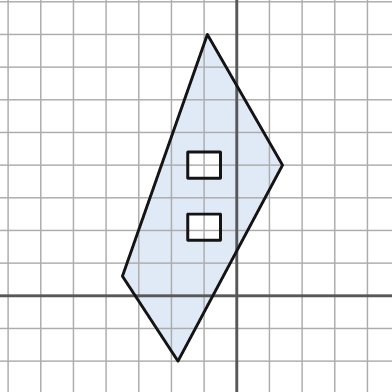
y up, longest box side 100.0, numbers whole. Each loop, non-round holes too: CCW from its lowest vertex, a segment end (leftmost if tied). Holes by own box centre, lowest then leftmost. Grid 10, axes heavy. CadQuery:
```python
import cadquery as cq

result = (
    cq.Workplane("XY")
    .moveTo(-18.0, -20.0)
    .lineTo(14.0, 40.0)
    .lineTo(-9.0, 80.0)
    .lineTo(-35.0, 6.0)
    .close()
    .moveTo(-15.0, 17.0)
    .lineTo(-5.0, 17.0)
    .lineTo(-5.0, 25.0)
    .lineTo(-15.0, 25.0)
    .close()
    .moveTo(-15.0, 36.0)
    .lineTo(-5.0, 36.0)
    .lineTo(-5.0, 44.0)
    .lineTo(-15.0, 44.0)
    .close()
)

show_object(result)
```